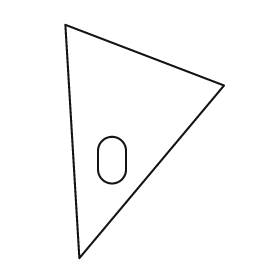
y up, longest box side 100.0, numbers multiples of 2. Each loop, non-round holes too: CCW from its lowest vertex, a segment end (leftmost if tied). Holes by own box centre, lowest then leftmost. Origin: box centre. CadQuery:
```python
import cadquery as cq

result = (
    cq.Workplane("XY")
    .moveTo(-28.0, -50.0)
    .lineTo(34.0, 24.0)
    .lineTo(-34.0, 50.0)
    .close()
    .moveTo(-20.0, -12.0)
    .threePointArc((-14.0, -18.0), (-8.0, -12.0))
    .lineTo(-8.0, -4.0)
    .threePointArc((-14.0, 2.0), (-20.0, -4.0))
    .close()
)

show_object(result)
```